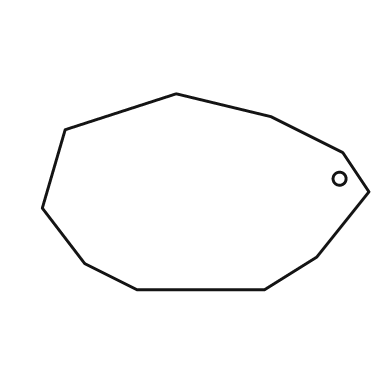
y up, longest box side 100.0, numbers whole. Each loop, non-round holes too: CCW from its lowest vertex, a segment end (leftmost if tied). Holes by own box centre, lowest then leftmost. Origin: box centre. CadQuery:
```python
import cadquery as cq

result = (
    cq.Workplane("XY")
    .moveTo(-21.0, -30.0)
    .lineTo(18.0, -30.0)
    .lineTo(34.0, -20.0)
    .lineTo(50.0, 0.0)
    .lineTo(42.0, 12.0)
    .lineTo(20.0, 23.0)
    .lineTo(-9.0, 30.0)
    .lineTo(-43.0, 19.0)
    .lineTo(-50.0, -5.0)
    .lineTo(-37.0, -22.0)
    .close()
    .moveTo(41.0, 4.0)
    .circle(2.0)
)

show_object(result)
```